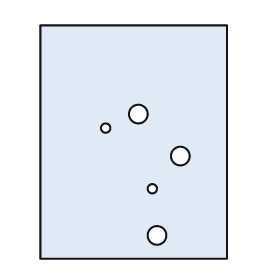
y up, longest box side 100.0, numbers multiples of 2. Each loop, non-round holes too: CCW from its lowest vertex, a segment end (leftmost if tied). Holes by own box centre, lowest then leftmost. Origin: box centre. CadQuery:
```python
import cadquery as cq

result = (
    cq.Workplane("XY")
    .moveTo(-40.0, -50.0)
    .lineTo(40.0, -50.0)
    .lineTo(40.0, 50.0)
    .lineTo(-40.0, 50.0)
    .close()
    .moveTo(10.0, -40.0)
    .circle(4.0)
    .moveTo(8.0, -20.0)
    .circle(2.0)
    .moveTo(20.0, -6.0)
    .circle(4.0)
    .moveTo(-12.0, 6.0)
    .circle(2.0)
    .moveTo(2.0, 12.0)
    .circle(4.0)
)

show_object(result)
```